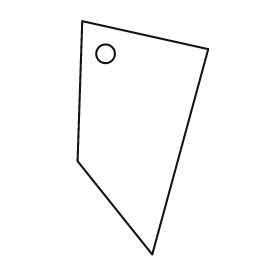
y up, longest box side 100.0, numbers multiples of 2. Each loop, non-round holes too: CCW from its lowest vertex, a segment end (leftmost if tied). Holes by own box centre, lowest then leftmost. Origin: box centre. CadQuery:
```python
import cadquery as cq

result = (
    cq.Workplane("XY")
    .moveTo(4.0, -50.0)
    .lineTo(28.0, 38.0)
    .lineTo(-26.0, 50.0)
    .lineTo(-28.0, -10.0)
    .close()
    .moveTo(-16.0, 36.0)
    .circle(4.0)
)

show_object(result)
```